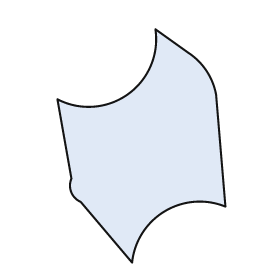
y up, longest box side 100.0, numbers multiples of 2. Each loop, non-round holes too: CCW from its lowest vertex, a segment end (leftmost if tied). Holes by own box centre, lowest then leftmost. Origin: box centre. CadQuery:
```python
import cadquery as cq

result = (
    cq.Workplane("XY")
    .moveTo(-4.0, -50.0)
    .threePointArc((10.0, -28.0), (36.0, -26.0))
    .lineTo(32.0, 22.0)
    .threePointArc((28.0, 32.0), (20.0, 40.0))
    .lineTo(6.0, 50.0)
    .threePointArc((-6.0, 22.0), (-36.0, 20.0))
    .lineTo(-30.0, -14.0)
    .threePointArc((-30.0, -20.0), (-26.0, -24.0))
    .close()
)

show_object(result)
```